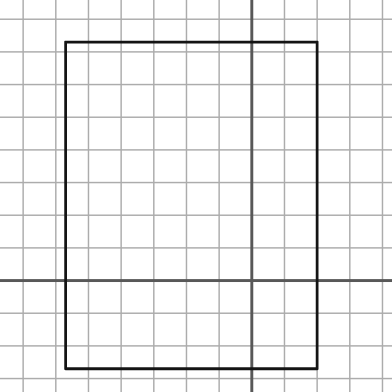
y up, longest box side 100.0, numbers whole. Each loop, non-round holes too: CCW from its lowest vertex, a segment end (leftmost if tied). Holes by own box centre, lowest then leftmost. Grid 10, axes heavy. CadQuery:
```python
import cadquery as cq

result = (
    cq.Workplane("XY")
    .moveTo(-57.0, -27.0)
    .lineTo(20.0, -27.0)
    .lineTo(20.0, 73.0)
    .lineTo(-57.0, 73.0)
    .close()
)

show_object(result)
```